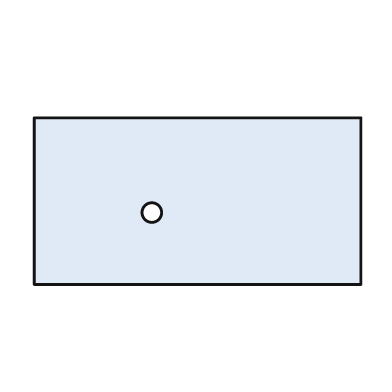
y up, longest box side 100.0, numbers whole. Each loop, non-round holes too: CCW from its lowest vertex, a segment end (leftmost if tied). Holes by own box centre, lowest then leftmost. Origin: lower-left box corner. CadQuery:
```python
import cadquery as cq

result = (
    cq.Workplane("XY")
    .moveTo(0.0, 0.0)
    .lineTo(100.0, 0.0)
    .lineTo(100.0, 51.0)
    .lineTo(0.0, 51.0)
    .close()
    .moveTo(36.0, 22.0)
    .circle(3.0)
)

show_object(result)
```